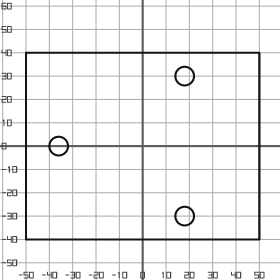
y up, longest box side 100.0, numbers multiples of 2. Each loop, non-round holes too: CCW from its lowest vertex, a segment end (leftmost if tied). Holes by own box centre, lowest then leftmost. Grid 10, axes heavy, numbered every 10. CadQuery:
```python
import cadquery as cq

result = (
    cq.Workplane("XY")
    .moveTo(-50.0, -40.0)
    .lineTo(50.0, -40.0)
    .lineTo(50.0, 40.0)
    .lineTo(-50.0, 40.0)
    .close()
    .moveTo(18.0, -30.0)
    .circle(4.0)
    .moveTo(-36.0, 0.0)
    .circle(4.0)
    .moveTo(18.0, 30.0)
    .circle(4.0)
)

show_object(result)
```